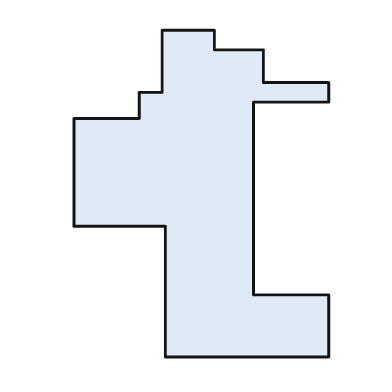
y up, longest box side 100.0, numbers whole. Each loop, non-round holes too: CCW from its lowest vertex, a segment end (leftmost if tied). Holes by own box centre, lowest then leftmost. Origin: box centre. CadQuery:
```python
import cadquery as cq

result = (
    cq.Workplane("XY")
    .moveTo(-11.0, -50.0)
    .lineTo(39.0, -50.0)
    .lineTo(39.0, -31.0)
    .lineTo(16.0, -31.0)
    .lineTo(16.0, 28.0)
    .lineTo(39.0, 28.0)
    .lineTo(39.0, 34.0)
    .lineTo(19.0, 34.0)
    .lineTo(19.0, 44.0)
    .lineTo(4.0, 44.0)
    .lineTo(4.0, 50.0)
    .lineTo(-12.0, 50.0)
    .lineTo(-12.0, 31.0)
    .lineTo(-19.0, 31.0)
    .lineTo(-19.0, 23.0)
    .lineTo(-39.0, 23.0)
    .lineTo(-39.0, -10.0)
    .lineTo(-11.0, -10.0)
    .close()
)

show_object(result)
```